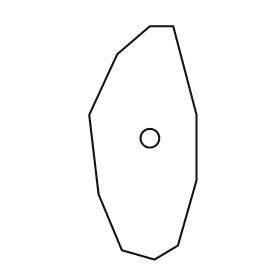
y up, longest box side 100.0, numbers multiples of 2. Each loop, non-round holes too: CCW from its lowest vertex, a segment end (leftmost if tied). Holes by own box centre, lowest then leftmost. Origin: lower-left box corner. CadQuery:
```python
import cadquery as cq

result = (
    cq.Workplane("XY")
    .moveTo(28.0, 0.0)
    .lineTo(38.0, 6.0)
    .lineTo(46.0, 34.0)
    .lineTo(46.0, 62.0)
    .lineTo(36.0, 100.0)
    .lineTo(26.0, 100.0)
    .lineTo(12.0, 88.0)
    .lineTo(0.0, 62.0)
    .lineTo(4.0, 28.0)
    .lineTo(14.0, 4.0)
    .close()
    .moveTo(26.0, 52.0)
    .circle(4.0)
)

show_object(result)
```